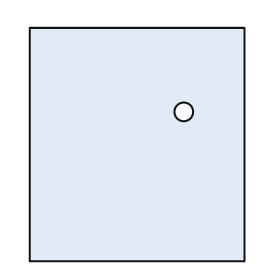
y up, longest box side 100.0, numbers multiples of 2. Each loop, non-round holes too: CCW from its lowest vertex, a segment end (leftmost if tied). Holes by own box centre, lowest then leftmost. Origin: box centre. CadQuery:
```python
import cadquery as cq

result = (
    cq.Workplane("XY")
    .moveTo(-46.0, -50.0)
    .lineTo(46.0, -50.0)
    .lineTo(46.0, 50.0)
    .lineTo(-46.0, 50.0)
    .close()
    .moveTo(20.0, 14.0)
    .circle(4.0)
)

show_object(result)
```